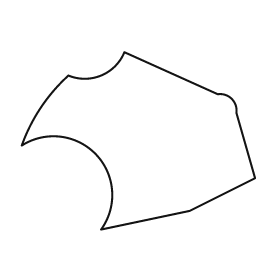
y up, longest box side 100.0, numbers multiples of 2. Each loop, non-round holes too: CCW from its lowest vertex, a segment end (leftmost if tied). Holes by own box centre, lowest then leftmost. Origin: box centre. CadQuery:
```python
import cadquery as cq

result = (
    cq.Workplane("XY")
    .moveTo(-16.0, -38.0)
    .lineTo(22.0, -30.0)
    .lineTo(50.0, -16.0)
    .lineTo(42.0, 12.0)
    .threePointArc((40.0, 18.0), (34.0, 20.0))
    .lineTo(-6.0, 38.0)
    .threePointArc((-16.0, 28.0), (-30.0, 28.0))
    .threePointArc((-42.0, 14.0), (-50.0, -2.0))
    .threePointArc((-18.0, -6.0), (-16.0, -38.0))
    .close()
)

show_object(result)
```